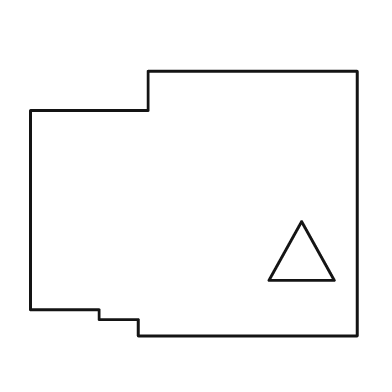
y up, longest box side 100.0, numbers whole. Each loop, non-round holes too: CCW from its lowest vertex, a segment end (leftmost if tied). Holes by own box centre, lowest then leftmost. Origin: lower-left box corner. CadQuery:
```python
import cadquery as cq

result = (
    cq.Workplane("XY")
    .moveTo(33.0, 0.0)
    .lineTo(100.0, 0.0)
    .lineTo(100.0, 81.0)
    .lineTo(36.0, 81.0)
    .lineTo(36.0, 69.0)
    .lineTo(0.0, 69.0)
    .lineTo(0.0, 8.0)
    .lineTo(21.0, 8.0)
    .lineTo(21.0, 5.0)
    .lineTo(33.0, 5.0)
    .close()
    .moveTo(73.0, 17.0)
    .lineTo(93.0, 17.0)
    .lineTo(83.0, 35.0)
    .close()
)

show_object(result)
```